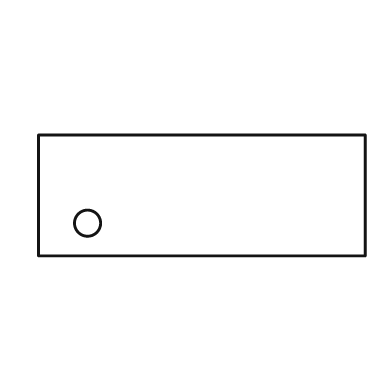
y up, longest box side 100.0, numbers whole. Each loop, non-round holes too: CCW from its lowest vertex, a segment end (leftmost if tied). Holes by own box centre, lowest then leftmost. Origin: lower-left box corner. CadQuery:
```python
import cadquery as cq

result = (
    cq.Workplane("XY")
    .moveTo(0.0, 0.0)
    .lineTo(100.0, 0.0)
    .lineTo(100.0, 37.0)
    .lineTo(0.0, 37.0)
    .close()
    .moveTo(15.0, 10.0)
    .circle(4.0)
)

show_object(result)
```